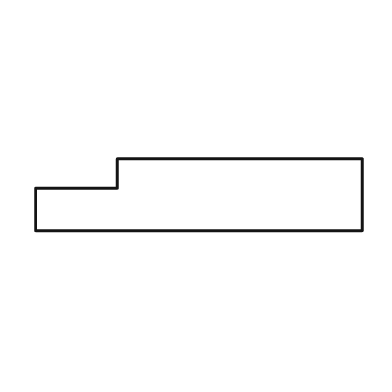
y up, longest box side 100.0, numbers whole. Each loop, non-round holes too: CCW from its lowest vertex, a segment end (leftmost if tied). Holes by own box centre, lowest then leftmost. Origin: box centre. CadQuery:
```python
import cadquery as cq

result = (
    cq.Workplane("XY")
    .moveTo(-50.0, -11.0)
    .lineTo(50.0, -11.0)
    .lineTo(50.0, 11.0)
    .lineTo(-25.0, 11.0)
    .lineTo(-25.0, 2.0)
    .lineTo(-50.0, 2.0)
    .close()
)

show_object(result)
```